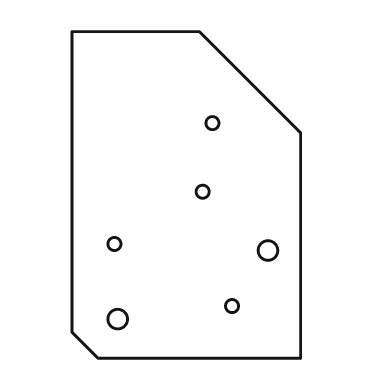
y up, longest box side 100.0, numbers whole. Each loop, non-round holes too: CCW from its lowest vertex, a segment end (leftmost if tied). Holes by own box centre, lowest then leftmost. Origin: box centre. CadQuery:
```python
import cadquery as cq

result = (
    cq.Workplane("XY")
    .moveTo(-27.0, -50.0)
    .lineTo(35.0, -50.0)
    .lineTo(35.0, 19.0)
    .lineTo(4.0, 50.0)
    .lineTo(-35.0, 50.0)
    .lineTo(-35.0, -42.0)
    .close()
    .moveTo(-21.0, -38.0)
    .circle(3.0)
    .moveTo(14.0, -34.0)
    .circle(2.0)
    .moveTo(25.0, -17.0)
    .circle(3.0)
    .moveTo(-22.0, -15.0)
    .circle(2.0)
    .moveTo(5.0, 1.0)
    .circle(2.0)
    .moveTo(8.0, 22.0)
    .circle(2.0)
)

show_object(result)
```